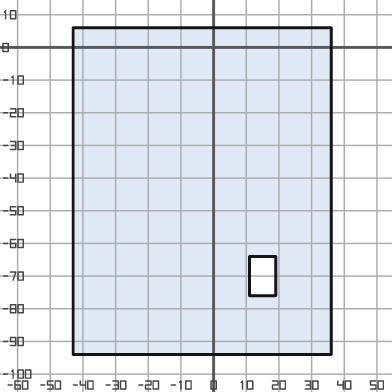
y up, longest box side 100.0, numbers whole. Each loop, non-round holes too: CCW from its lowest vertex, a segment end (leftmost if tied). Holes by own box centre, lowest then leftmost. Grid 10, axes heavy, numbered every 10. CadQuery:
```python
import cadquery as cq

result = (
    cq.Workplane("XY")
    .moveTo(-43.0, -94.0)
    .lineTo(36.0, -94.0)
    .lineTo(36.0, 6.0)
    .lineTo(-43.0, 6.0)
    .close()
    .moveTo(11.0, -76.0)
    .lineTo(19.0, -76.0)
    .lineTo(19.0, -64.0)
    .lineTo(11.0, -64.0)
    .close()
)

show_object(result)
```